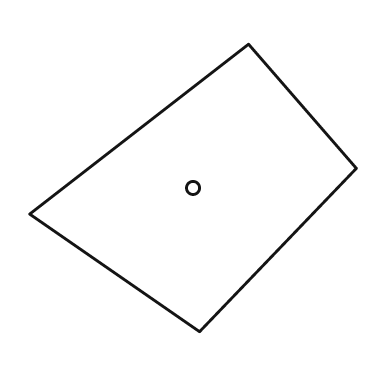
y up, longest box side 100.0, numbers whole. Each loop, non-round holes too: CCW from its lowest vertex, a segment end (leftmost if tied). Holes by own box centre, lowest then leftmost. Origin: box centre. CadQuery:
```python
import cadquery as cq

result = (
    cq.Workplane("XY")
    .moveTo(2.0, -44.0)
    .lineTo(50.0, 6.0)
    .lineTo(17.0, 44.0)
    .lineTo(-50.0, -8.0)
    .close()
    .moveTo(0.0, 0.0)
    .circle(2.0)
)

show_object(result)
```